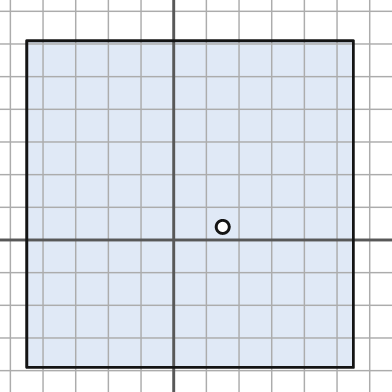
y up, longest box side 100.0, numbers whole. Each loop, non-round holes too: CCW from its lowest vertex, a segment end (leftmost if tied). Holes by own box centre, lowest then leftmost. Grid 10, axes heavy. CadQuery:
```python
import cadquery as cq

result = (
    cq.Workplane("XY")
    .moveTo(-45.0, -39.0)
    .lineTo(55.0, -39.0)
    .lineTo(55.0, 61.0)
    .lineTo(-45.0, 61.0)
    .close()
    .moveTo(15.0, 4.0)
    .circle(2.0)
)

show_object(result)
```